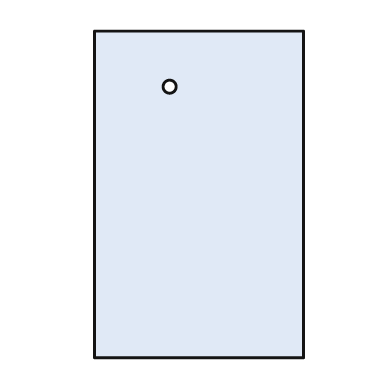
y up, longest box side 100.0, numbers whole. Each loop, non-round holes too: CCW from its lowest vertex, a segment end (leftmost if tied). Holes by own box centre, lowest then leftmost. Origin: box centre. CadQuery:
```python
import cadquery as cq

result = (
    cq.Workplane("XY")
    .moveTo(-32.0, -50.0)
    .lineTo(32.0, -50.0)
    .lineTo(32.0, 50.0)
    .lineTo(-32.0, 50.0)
    .close()
    .moveTo(-9.0, 33.0)
    .circle(2.0)
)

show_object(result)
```